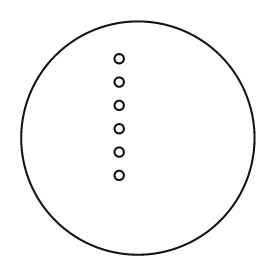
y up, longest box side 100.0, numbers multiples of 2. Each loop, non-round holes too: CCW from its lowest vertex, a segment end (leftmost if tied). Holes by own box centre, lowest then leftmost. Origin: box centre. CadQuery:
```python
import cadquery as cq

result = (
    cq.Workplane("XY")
    .moveTo(0.0, 0.0)
    .circle(50.0)
    .moveTo(-8.0, -16.0)
    .circle(2.0)
    .moveTo(-8.0, -6.0)
    .circle(2.0)
    .moveTo(-8.0, 4.0)
    .circle(2.0)
    .moveTo(-8.0, 14.0)
    .circle(2.0)
    .moveTo(-8.0, 24.0)
    .circle(2.0)
    .moveTo(-8.0, 34.0)
    .circle(2.0)
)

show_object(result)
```